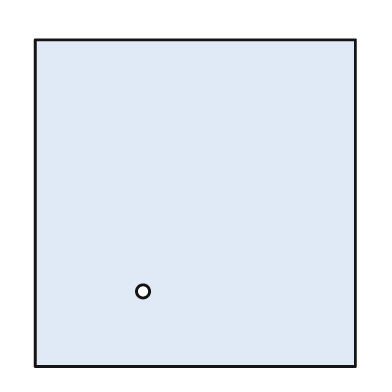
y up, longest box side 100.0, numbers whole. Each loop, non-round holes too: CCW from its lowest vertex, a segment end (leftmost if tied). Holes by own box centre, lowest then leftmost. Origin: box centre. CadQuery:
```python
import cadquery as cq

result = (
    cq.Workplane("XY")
    .moveTo(-49.0, -50.0)
    .lineTo(49.0, -50.0)
    .lineTo(49.0, 50.0)
    .lineTo(-49.0, 50.0)
    .close()
    .moveTo(-16.0, -27.0)
    .circle(2.0)
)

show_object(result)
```